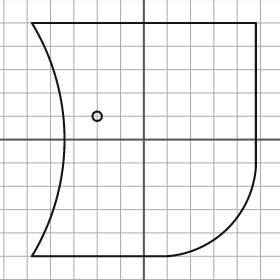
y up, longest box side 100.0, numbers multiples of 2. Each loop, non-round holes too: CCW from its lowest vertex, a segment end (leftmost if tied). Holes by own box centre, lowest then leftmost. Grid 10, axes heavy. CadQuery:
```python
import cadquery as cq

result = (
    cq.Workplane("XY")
    .moveTo(-48.0, -50.0)
    .lineTo(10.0, -50.0)
    .threePointArc((36.0, -38.0), (48.0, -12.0))
    .lineTo(48.0, 50.0)
    .lineTo(-48.0, 50.0)
    .threePointArc((-34.0, 0.0), (-48.0, -50.0))
    .close()
    .moveTo(-20.0, 10.0)
    .circle(2.0)
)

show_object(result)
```